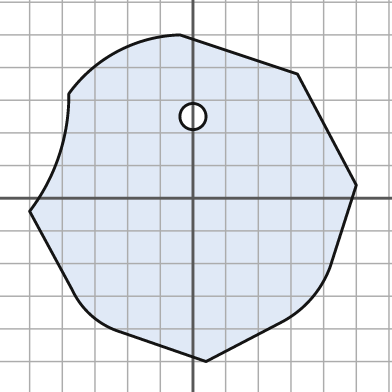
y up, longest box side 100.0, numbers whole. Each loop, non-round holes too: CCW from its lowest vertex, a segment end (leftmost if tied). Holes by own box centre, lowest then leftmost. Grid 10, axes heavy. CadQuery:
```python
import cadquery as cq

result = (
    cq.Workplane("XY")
    .moveTo(4.0, -50.0)
    .lineTo(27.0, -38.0)
    .threePointArc((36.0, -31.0), (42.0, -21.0))
    .lineTo(50.0, 4.0)
    .lineTo(32.0, 38.0)
    .lineTo(-4.0, 50.0)
    .threePointArc((-23.0, 45.0), (-38.0, 32.0))
    .threePointArc((-41.0, 13.0), (-50.0, -4.0))
    .lineTo(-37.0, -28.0)
    .threePointArc((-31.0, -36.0), (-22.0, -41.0))
    .close()
    .moveTo(0.0, 25.0)
    .circle(4.0)
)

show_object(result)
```